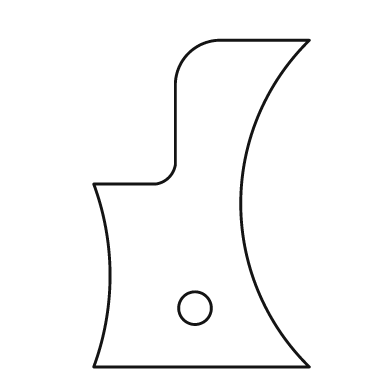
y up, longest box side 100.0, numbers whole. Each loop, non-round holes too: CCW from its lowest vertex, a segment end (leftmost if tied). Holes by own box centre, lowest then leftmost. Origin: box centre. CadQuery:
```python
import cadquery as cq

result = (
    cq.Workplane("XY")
    .moveTo(-33.0, -50.0)
    .lineTo(33.0, -50.0)
    .threePointArc((12.0, 0.0), (33.0, 50.0))
    .lineTo(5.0, 50.0)
    .threePointArc((-4.0, 46.0), (-8.0, 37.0))
    .lineTo(-8.0, 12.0)
    .threePointArc((-10.0, 8.0), (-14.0, 6.0))
    .lineTo(-33.0, 6.0)
    .threePointArc((-28.0, -22.0), (-33.0, -50.0))
    .close()
    .moveTo(-2.0, -32.0)
    .circle(5.0)
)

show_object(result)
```